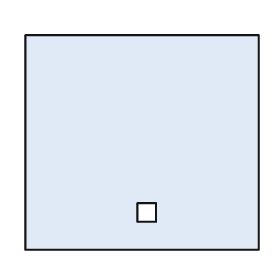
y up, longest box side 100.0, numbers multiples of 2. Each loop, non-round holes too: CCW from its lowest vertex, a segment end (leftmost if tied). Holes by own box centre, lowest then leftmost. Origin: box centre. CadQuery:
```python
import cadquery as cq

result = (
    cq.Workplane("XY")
    .moveTo(-50.0, -46.0)
    .lineTo(50.0, -46.0)
    .lineTo(50.0, 46.0)
    .lineTo(-50.0, 46.0)
    .close()
    .moveTo(-2.0, -34.0)
    .lineTo(6.0, -34.0)
    .lineTo(6.0, -26.0)
    .lineTo(-2.0, -26.0)
    .close()
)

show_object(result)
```